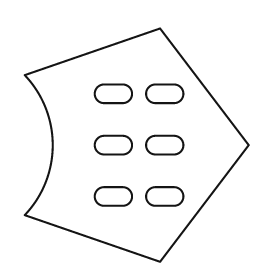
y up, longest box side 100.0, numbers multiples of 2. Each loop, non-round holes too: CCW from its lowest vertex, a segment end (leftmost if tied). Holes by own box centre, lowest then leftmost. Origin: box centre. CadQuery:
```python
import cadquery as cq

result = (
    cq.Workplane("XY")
    .moveTo(10.0, -50.0)
    .lineTo(48.0, 0.0)
    .lineTo(10.0, 50.0)
    .lineTo(-48.0, 30.0)
    .threePointArc((-36.0, 0.0), (-48.0, -30.0))
    .close()
    .moveTo(-14.0, -26.0)
    .lineTo(-6.0, -26.0)
    .threePointArc((-2.0, -22.0), (-6.0, -18.0))
    .lineTo(-14.0, -18.0)
    .threePointArc((-18.0, -22.0), (-14.0, -26.0))
    .close()
    .moveTo(8.0, -26.0)
    .lineTo(16.0, -26.0)
    .threePointArc((20.0, -22.0), (16.0, -18.0))
    .lineTo(8.0, -18.0)
    .threePointArc((4.0, -22.0), (8.0, -26.0))
    .close()
    .moveTo(-14.0, -4.0)
    .lineTo(-6.0, -4.0)
    .threePointArc((-2.0, 0.0), (-6.0, 4.0))
    .lineTo(-14.0, 4.0)
    .threePointArc((-18.0, 0.0), (-14.0, -4.0))
    .close()
    .moveTo(8.0, -4.0)
    .lineTo(16.0, -4.0)
    .threePointArc((20.0, 0.0), (16.0, 4.0))
    .lineTo(8.0, 4.0)
    .threePointArc((4.0, 0.0), (8.0, -4.0))
    .close()
    .moveTo(-14.0, 18.0)
    .lineTo(-6.0, 18.0)
    .threePointArc((-2.0, 22.0), (-6.0, 26.0))
    .lineTo(-14.0, 26.0)
    .threePointArc((-18.0, 22.0), (-14.0, 18.0))
    .close()
    .moveTo(8.0, 18.0)
    .lineTo(16.0, 18.0)
    .threePointArc((20.0, 22.0), (16.0, 26.0))
    .lineTo(8.0, 26.0)
    .threePointArc((4.0, 22.0), (8.0, 18.0))
    .close()
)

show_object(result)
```